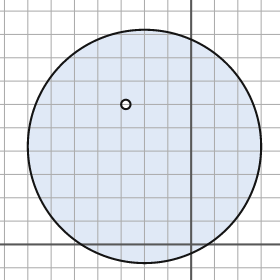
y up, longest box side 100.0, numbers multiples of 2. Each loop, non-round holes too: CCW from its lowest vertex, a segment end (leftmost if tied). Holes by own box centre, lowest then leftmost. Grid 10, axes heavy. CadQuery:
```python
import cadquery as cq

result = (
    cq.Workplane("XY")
    .moveTo(-20.0, 42.0)
    .circle(50.0)
    .moveTo(-28.0, 60.0)
    .circle(2.0)
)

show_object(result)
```